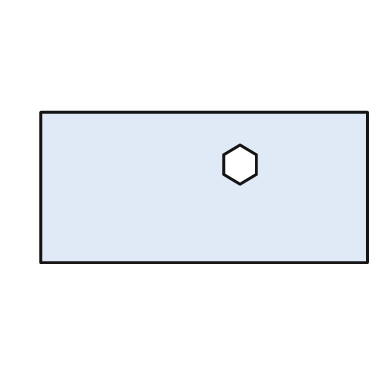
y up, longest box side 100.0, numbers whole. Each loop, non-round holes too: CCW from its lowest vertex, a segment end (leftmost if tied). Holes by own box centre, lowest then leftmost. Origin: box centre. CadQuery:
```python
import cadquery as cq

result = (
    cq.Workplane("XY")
    .moveTo(-50.0, -23.0)
    .lineTo(50.0, -23.0)
    .lineTo(50.0, 23.0)
    .lineTo(-50.0, 23.0)
    .close()
    .moveTo(11.0, 1.0)
    .lineTo(16.0, 4.0)
    .lineTo(16.0, 10.0)
    .lineTo(11.0, 13.0)
    .lineTo(6.0, 10.0)
    .lineTo(6.0, 4.0)
    .close()
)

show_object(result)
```